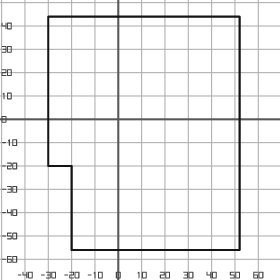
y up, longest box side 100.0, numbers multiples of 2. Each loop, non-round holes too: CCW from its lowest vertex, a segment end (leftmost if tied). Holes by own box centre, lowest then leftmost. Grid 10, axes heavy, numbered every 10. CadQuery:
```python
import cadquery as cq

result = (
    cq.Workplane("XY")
    .moveTo(-20.0, -56.0)
    .lineTo(52.0, -56.0)
    .lineTo(52.0, 44.0)
    .lineTo(-30.0, 44.0)
    .lineTo(-30.0, -20.0)
    .lineTo(-20.0, -20.0)
    .close()
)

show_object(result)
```